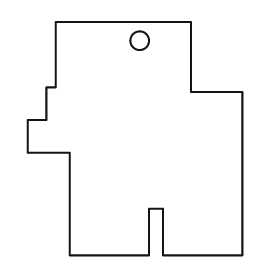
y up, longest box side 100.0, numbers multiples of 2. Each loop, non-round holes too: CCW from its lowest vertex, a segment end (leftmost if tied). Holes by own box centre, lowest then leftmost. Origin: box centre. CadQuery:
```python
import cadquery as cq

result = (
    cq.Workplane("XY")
    .moveTo(-28.0, -50.0)
    .lineTo(6.0, -50.0)
    .lineTo(6.0, -30.0)
    .lineTo(12.0, -30.0)
    .lineTo(12.0, -50.0)
    .lineTo(46.0, -50.0)
    .lineTo(46.0, 20.0)
    .lineTo(24.0, 20.0)
    .lineTo(24.0, 50.0)
    .lineTo(-34.0, 50.0)
    .lineTo(-34.0, 22.0)
    .lineTo(-38.0, 22.0)
    .lineTo(-38.0, 8.0)
    .lineTo(-46.0, 8.0)
    .lineTo(-46.0, -6.0)
    .lineTo(-28.0, -6.0)
    .close()
    .moveTo(2.0, 42.0)
    .circle(4.0)
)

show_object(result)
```